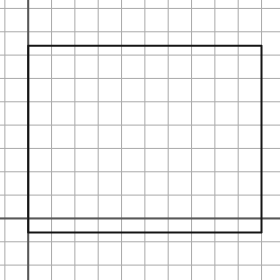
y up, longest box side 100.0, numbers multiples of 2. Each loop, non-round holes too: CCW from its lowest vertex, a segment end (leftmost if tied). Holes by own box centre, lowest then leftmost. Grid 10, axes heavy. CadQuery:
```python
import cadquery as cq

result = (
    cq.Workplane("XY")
    .moveTo(0.0, -6.0)
    .lineTo(100.0, -6.0)
    .lineTo(100.0, 74.0)
    .lineTo(0.0, 74.0)
    .close()
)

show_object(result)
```